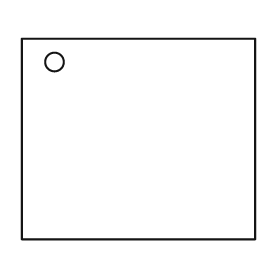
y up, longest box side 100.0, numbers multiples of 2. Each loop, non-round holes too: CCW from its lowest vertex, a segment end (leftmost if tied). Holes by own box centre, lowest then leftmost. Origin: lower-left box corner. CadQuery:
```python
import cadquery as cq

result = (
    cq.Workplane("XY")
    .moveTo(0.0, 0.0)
    .lineTo(100.0, 0.0)
    .lineTo(100.0, 86.0)
    .lineTo(0.0, 86.0)
    .close()
    .moveTo(14.0, 76.0)
    .circle(4.0)
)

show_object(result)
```